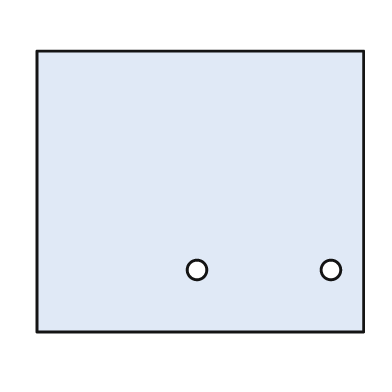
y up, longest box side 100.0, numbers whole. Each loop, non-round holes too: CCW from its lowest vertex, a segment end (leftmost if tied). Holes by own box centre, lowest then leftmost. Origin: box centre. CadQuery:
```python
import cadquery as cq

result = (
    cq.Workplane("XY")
    .moveTo(-50.0, -43.0)
    .lineTo(50.0, -43.0)
    .lineTo(50.0, 43.0)
    .lineTo(-50.0, 43.0)
    .close()
    .moveTo(-1.0, -24.0)
    .circle(3.0)
    .moveTo(40.0, -24.0)
    .circle(3.0)
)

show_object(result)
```